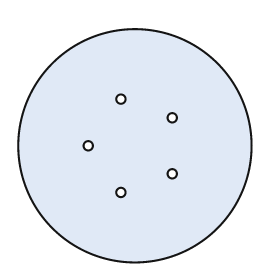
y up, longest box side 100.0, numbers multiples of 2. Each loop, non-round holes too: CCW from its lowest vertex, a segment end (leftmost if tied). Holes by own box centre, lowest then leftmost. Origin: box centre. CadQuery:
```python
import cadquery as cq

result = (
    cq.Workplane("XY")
    .moveTo(0.0, 0.0)
    .circle(50.0)
    .moveTo(-6.0, -20.0)
    .circle(2.0)
    .moveTo(16.0, -12.0)
    .circle(2.0)
    .moveTo(-20.0, 0.0)
    .circle(2.0)
    .moveTo(16.0, 12.0)
    .circle(2.0)
    .moveTo(-6.0, 20.0)
    .circle(2.0)
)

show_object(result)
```